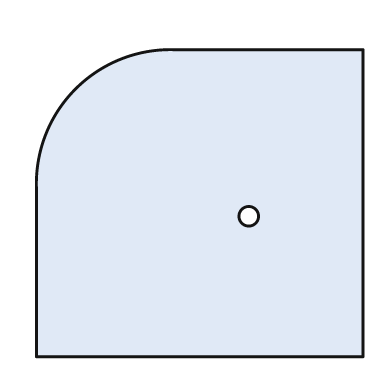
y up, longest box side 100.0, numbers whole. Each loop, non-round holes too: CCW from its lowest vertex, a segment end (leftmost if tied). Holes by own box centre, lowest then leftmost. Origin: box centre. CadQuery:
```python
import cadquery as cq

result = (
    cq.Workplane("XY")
    .moveTo(-50.0, -47.0)
    .lineTo(50.0, -47.0)
    .lineTo(50.0, 47.0)
    .lineTo(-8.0, 47.0)
    .threePointArc((-38.0, 35.0), (-50.0, 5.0))
    .close()
    .moveTo(15.0, -4.0)
    .circle(3.0)
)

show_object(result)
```